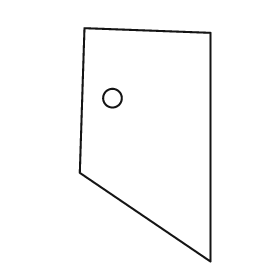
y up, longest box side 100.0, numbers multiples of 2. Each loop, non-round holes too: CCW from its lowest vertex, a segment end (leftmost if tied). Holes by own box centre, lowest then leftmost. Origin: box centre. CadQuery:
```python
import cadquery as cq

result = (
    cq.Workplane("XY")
    .moveTo(28.0, -50.0)
    .lineTo(28.0, 48.0)
    .lineTo(-26.0, 50.0)
    .lineTo(-28.0, -12.0)
    .close()
    .moveTo(-14.0, 20.0)
    .circle(4.0)
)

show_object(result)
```